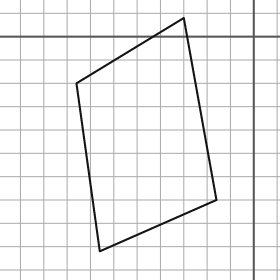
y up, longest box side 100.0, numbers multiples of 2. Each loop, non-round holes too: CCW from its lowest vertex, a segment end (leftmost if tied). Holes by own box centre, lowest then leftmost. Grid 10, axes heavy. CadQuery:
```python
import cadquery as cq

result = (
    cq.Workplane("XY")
    .moveTo(-66.0, -92.0)
    .lineTo(-16.0, -70.0)
    .lineTo(-30.0, 8.0)
    .lineTo(-76.0, -20.0)
    .close()
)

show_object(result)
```